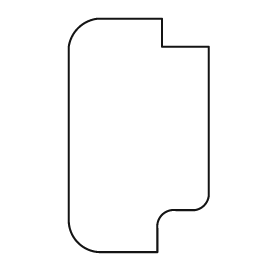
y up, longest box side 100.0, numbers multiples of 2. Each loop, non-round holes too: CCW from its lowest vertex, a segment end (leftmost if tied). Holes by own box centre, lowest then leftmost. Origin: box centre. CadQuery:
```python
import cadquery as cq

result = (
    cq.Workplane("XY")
    .moveTo(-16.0, -50.0)
    .lineTo(8.0, -50.0)
    .lineTo(8.0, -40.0)
    .threePointArc((10.0, -34.0), (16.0, -32.0))
    .lineTo(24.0, -32.0)
    .threePointArc((28.0, -30.0), (30.0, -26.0))
    .lineTo(30.0, 38.0)
    .lineTo(10.0, 38.0)
    .lineTo(10.0, 50.0)
    .lineTo(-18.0, 50.0)
    .threePointArc((-26.0, 46.0), (-30.0, 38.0))
    .lineTo(-30.0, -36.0)
    .threePointArc((-26.0, -46.0), (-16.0, -50.0))
    .close()
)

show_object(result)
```